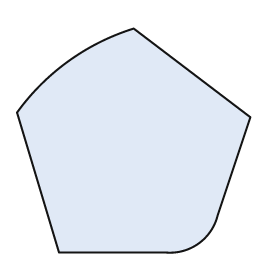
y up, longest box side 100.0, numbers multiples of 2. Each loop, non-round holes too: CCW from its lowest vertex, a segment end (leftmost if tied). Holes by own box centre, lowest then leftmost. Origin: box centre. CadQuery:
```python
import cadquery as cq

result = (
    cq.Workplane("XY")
    .moveTo(-32.0, -48.0)
    .lineTo(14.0, -48.0)
    .threePointArc((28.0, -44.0), (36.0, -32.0))
    .lineTo(50.0, 10.0)
    .lineTo(0.0, 48.0)
    .threePointArc((-28.0, 34.0), (-50.0, 12.0))
    .close()
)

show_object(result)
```